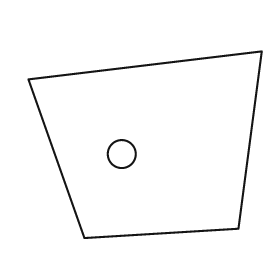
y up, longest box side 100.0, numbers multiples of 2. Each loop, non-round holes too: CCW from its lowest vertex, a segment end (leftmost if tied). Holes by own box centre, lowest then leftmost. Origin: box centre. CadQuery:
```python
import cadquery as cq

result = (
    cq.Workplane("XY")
    .moveTo(-26.0, -40.0)
    .lineTo(40.0, -36.0)
    .lineTo(50.0, 40.0)
    .lineTo(-50.0, 28.0)
    .close()
    .moveTo(-10.0, -4.0)
    .circle(6.0)
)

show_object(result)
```